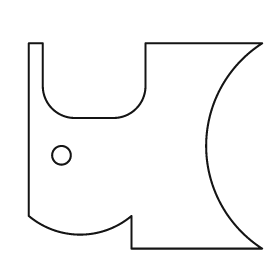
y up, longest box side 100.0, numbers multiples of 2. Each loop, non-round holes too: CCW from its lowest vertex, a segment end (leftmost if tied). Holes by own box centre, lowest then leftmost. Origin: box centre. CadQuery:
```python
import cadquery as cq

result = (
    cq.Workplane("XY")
    .moveTo(-6.0, -44.0)
    .lineTo(50.0, -44.0)
    .threePointArc((26.0, 0.0), (50.0, 44.0))
    .lineTo(0.0, 44.0)
    .lineTo(0.0, 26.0)
    .threePointArc((-4.0, 16.0), (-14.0, 12.0))
    .lineTo(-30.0, 12.0)
    .threePointArc((-40.0, 16.0), (-44.0, 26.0))
    .lineTo(-44.0, 44.0)
    .lineTo(-50.0, 44.0)
    .lineTo(-50.0, -30.0)
    .threePointArc((-28.0, -38.0), (-6.0, -30.0))
    .close()
    .moveTo(-36.0, -4.0)
    .circle(4.0)
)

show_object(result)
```